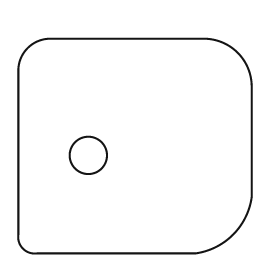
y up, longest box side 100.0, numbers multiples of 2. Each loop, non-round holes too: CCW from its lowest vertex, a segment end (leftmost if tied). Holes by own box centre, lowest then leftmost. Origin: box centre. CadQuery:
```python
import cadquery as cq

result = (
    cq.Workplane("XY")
    .moveTo(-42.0, -46.0)
    .lineTo(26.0, -46.0)
    .threePointArc((42.0, -38.0), (50.0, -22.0))
    .lineTo(50.0, 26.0)
    .threePointArc((44.0, 40.0), (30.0, 46.0))
    .lineTo(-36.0, 46.0)
    .threePointArc((-46.0, 42.0), (-50.0, 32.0))
    .lineTo(-50.0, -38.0)
    .threePointArc((-48.0, -44.0), (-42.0, -46.0))
    .close()
    .moveTo(-20.0, -4.0)
    .circle(8.0)
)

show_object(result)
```